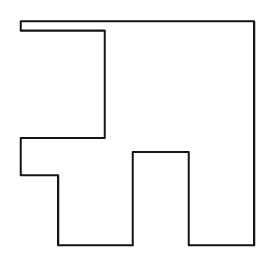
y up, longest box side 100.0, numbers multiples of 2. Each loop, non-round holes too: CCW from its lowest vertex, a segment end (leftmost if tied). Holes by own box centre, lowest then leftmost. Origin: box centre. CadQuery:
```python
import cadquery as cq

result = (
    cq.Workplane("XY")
    .moveTo(-34.0, -48.0)
    .lineTo(-2.0, -48.0)
    .lineTo(-2.0, -8.0)
    .lineTo(22.0, -8.0)
    .lineTo(22.0, -48.0)
    .lineTo(50.0, -48.0)
    .lineTo(50.0, 48.0)
    .lineTo(-50.0, 48.0)
    .lineTo(-50.0, 44.0)
    .lineTo(-14.0, 44.0)
    .lineTo(-14.0, -2.0)
    .lineTo(-50.0, -2.0)
    .lineTo(-50.0, -18.0)
    .lineTo(-34.0, -18.0)
    .close()
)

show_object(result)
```